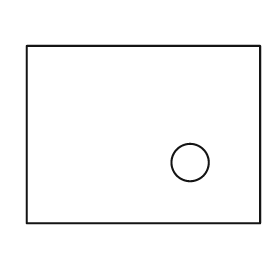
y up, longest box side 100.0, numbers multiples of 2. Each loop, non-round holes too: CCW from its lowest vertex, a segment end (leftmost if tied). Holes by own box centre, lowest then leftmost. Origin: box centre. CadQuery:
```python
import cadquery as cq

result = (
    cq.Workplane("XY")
    .moveTo(-50.0, -38.0)
    .lineTo(50.0, -38.0)
    .lineTo(50.0, 38.0)
    .lineTo(-50.0, 38.0)
    .close()
    .moveTo(20.0, -12.0)
    .circle(8.0)
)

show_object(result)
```